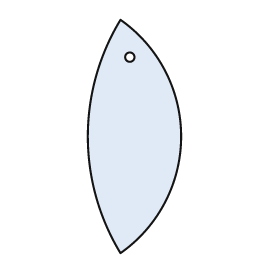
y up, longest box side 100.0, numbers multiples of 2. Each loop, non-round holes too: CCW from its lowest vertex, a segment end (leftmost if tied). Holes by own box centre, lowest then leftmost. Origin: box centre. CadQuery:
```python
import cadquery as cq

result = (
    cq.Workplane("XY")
    .moveTo(-6.0, -50.0)
    .threePointArc((20.0, 0.0), (-6.0, 50.0))
    .threePointArc((-20.0, 0.0), (-6.0, -50.0))
    .close()
    .moveTo(-2.0, 34.0)
    .circle(2.0)
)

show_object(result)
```